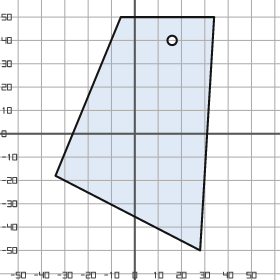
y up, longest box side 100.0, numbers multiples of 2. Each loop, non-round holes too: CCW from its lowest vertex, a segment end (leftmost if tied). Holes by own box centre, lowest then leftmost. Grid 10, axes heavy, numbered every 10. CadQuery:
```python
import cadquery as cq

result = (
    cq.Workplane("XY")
    .moveTo(28.0, -50.0)
    .lineTo(34.0, 50.0)
    .lineTo(-6.0, 50.0)
    .lineTo(-34.0, -18.0)
    .close()
    .moveTo(16.0, 40.0)
    .circle(2.0)
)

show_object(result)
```